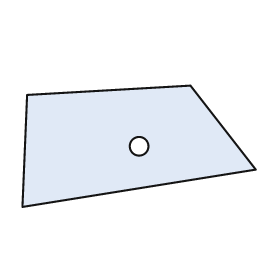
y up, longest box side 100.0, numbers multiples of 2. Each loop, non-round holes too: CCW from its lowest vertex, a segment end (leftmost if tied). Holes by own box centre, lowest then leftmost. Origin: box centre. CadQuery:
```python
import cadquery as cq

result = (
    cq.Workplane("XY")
    .moveTo(-50.0, -26.0)
    .lineTo(50.0, -10.0)
    .lineTo(22.0, 26.0)
    .lineTo(-48.0, 22.0)
    .close()
    .moveTo(0.0, 0.0)
    .circle(4.0)
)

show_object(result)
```